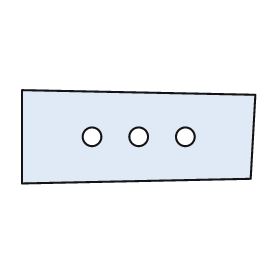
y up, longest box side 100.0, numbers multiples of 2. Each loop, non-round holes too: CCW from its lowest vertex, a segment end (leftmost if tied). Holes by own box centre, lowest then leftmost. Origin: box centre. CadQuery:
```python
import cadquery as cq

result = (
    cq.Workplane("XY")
    .moveTo(-50.0, -20.0)
    .lineTo(48.0, -18.0)
    .lineTo(50.0, 18.0)
    .lineTo(-50.0, 20.0)
    .close()
    .moveTo(-20.0, 0.0)
    .circle(4.0)
    .moveTo(0.0, 0.0)
    .circle(4.0)
    .moveTo(20.0, 0.0)
    .circle(4.0)
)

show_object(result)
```